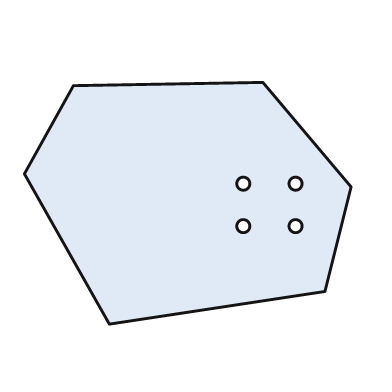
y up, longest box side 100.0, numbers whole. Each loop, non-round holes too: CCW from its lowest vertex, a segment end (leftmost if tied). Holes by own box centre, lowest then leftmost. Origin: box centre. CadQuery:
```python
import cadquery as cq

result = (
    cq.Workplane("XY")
    .moveTo(-24.0, -37.0)
    .lineTo(42.0, -27.0)
    .lineTo(50.0, 5.0)
    .lineTo(23.0, 37.0)
    .lineTo(-35.0, 36.0)
    .lineTo(-50.0, 9.0)
    .close()
    .moveTo(17.0, -7.0)
    .circle(2.0)
    .moveTo(33.0, -7.0)
    .circle(2.0)
    .moveTo(17.0, 6.0)
    .circle(2.0)
    .moveTo(33.0, 6.0)
    .circle(2.0)
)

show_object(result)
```